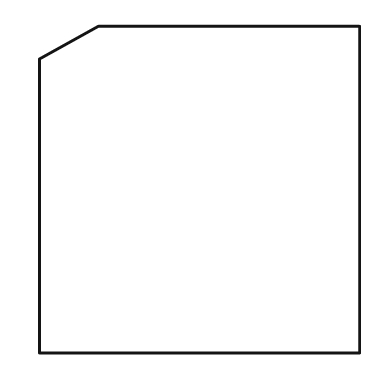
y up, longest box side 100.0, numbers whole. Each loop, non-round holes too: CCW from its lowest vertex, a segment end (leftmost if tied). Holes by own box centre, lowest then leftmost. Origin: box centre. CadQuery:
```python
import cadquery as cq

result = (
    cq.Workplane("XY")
    .moveTo(-49.0, -50.0)
    .lineTo(49.0, -50.0)
    .lineTo(49.0, 50.0)
    .lineTo(-31.0, 50.0)
    .lineTo(-49.0, 40.0)
    .close()
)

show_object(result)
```